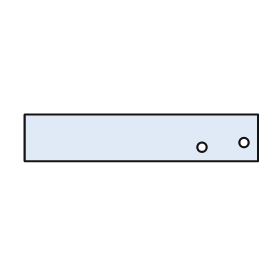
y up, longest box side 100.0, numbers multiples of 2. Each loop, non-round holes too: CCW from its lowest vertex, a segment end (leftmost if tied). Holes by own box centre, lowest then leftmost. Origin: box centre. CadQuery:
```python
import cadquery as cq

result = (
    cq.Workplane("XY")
    .moveTo(-50.0, -10.0)
    .lineTo(50.0, -10.0)
    .lineTo(50.0, 10.0)
    .lineTo(-50.0, 10.0)
    .close()
    .moveTo(26.0, -4.0)
    .circle(2.0)
    .moveTo(44.0, -2.0)
    .circle(2.0)
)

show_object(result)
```